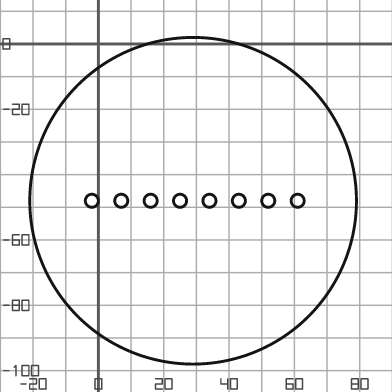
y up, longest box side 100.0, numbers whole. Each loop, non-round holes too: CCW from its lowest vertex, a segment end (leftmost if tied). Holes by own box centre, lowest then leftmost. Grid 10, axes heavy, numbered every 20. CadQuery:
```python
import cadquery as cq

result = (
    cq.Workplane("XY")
    .moveTo(29.0, -48.0)
    .circle(50.0)
    .moveTo(-2.0, -48.0)
    .circle(2.0)
    .moveTo(7.0, -48.0)
    .circle(2.0)
    .moveTo(16.0, -48.0)
    .circle(2.0)
    .moveTo(25.0, -48.0)
    .circle(2.0)
    .moveTo(34.0, -48.0)
    .circle(2.0)
    .moveTo(43.0, -48.0)
    .circle(2.0)
    .moveTo(52.0, -48.0)
    .circle(2.0)
    .moveTo(61.0, -48.0)
    .circle(2.0)
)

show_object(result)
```